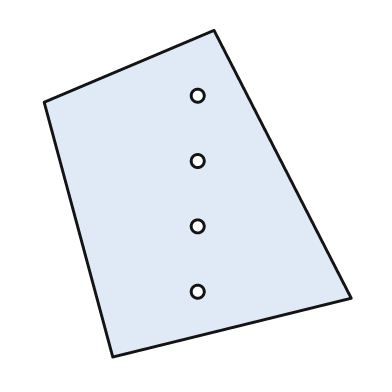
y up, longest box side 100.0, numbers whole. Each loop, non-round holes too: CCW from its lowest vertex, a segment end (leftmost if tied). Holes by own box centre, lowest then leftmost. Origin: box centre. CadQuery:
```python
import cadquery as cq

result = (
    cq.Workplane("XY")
    .moveTo(-26.0, -50.0)
    .lineTo(47.0, -32.0)
    .lineTo(5.0, 50.0)
    .lineTo(-47.0, 28.0)
    .close()
    .moveTo(0.0, -30.0)
    .circle(2.0)
    .moveTo(0.0, -10.0)
    .circle(2.0)
    .moveTo(0.0, 10.0)
    .circle(2.0)
    .moveTo(0.0, 30.0)
    .circle(2.0)
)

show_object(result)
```